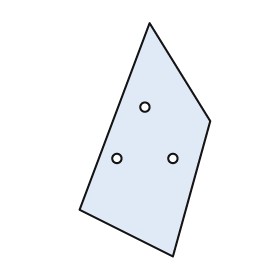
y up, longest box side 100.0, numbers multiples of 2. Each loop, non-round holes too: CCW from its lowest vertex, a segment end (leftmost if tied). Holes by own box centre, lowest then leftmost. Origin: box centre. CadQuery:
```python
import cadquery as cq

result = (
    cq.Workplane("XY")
    .moveTo(12.0, -50.0)
    .lineTo(28.0, 8.0)
    .lineTo(2.0, 50.0)
    .lineTo(-28.0, -30.0)
    .close()
    .moveTo(-12.0, -8.0)
    .circle(2.0)
    .moveTo(12.0, -8.0)
    .circle(2.0)
    .moveTo(0.0, 14.0)
    .circle(2.0)
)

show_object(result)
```